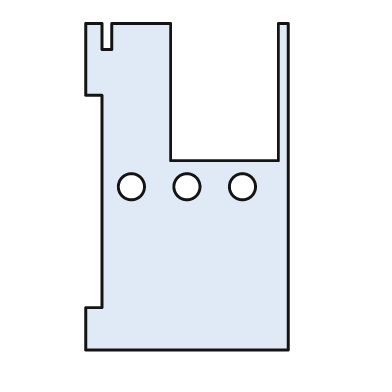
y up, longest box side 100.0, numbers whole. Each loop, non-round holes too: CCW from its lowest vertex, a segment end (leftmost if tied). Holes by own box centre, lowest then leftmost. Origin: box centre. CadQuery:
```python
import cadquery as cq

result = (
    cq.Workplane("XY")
    .moveTo(-31.0, -50.0)
    .lineTo(31.0, -50.0)
    .lineTo(31.0, 50.0)
    .lineTo(28.0, 50.0)
    .lineTo(28.0, 8.0)
    .lineTo(-5.0, 8.0)
    .lineTo(-5.0, 50.0)
    .lineTo(-23.0, 50.0)
    .lineTo(-23.0, 42.0)
    .lineTo(-26.0, 42.0)
    .lineTo(-26.0, 50.0)
    .lineTo(-31.0, 50.0)
    .lineTo(-31.0, 28.0)
    .lineTo(-26.0, 28.0)
    .lineTo(-26.0, -37.0)
    .lineTo(-31.0, -37.0)
    .close()
    .moveTo(-17.0, 0.0)
    .circle(4.0)
    .moveTo(0.0, 0.0)
    .circle(4.0)
    .moveTo(17.0, 0.0)
    .circle(4.0)
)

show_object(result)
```